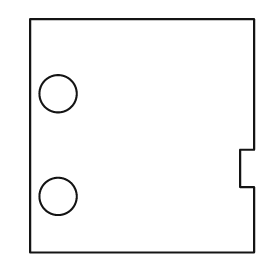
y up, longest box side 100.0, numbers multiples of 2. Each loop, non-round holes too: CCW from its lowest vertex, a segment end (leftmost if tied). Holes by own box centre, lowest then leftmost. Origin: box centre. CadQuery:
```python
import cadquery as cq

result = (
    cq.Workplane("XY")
    .moveTo(-48.0, -50.0)
    .lineTo(48.0, -50.0)
    .lineTo(48.0, -22.0)
    .lineTo(42.0, -22.0)
    .lineTo(42.0, -6.0)
    .lineTo(48.0, -6.0)
    .lineTo(48.0, 50.0)
    .lineTo(-48.0, 50.0)
    .close()
    .moveTo(-36.0, -26.0)
    .circle(8.0)
    .moveTo(-36.0, 18.0)
    .circle(8.0)
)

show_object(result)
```